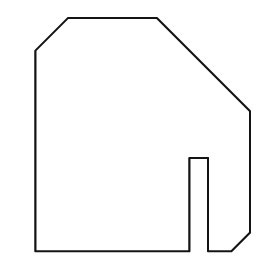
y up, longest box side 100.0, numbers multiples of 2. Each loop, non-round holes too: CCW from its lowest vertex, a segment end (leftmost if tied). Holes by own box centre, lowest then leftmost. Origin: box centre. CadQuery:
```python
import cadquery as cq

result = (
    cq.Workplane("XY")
    .moveTo(-46.0, -50.0)
    .lineTo(20.0, -50.0)
    .lineTo(20.0, -10.0)
    .lineTo(28.0, -10.0)
    .lineTo(28.0, -50.0)
    .lineTo(38.0, -50.0)
    .lineTo(46.0, -42.0)
    .lineTo(46.0, 10.0)
    .lineTo(6.0, 50.0)
    .lineTo(-32.0, 50.0)
    .lineTo(-46.0, 36.0)
    .close()
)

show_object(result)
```